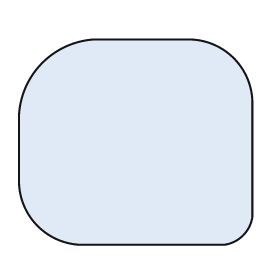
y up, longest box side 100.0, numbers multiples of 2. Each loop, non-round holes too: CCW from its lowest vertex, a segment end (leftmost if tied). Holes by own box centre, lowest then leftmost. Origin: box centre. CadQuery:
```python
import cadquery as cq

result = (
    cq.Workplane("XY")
    .moveTo(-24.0, -44.0)
    .lineTo(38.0, -44.0)
    .threePointArc((46.0, -40.0), (50.0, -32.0))
    .lineTo(50.0, 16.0)
    .threePointArc((42.0, 36.0), (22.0, 44.0))
    .lineTo(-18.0, 44.0)
    .threePointArc((-40.0, 34.0), (-50.0, 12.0))
    .lineTo(-50.0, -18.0)
    .threePointArc((-42.0, -36.0), (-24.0, -44.0))
    .close()
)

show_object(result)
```